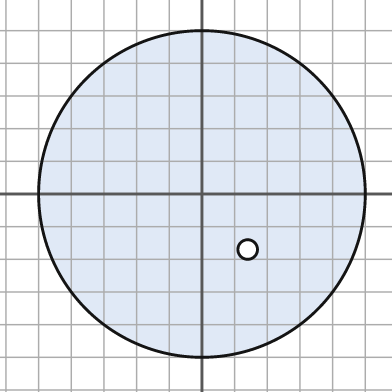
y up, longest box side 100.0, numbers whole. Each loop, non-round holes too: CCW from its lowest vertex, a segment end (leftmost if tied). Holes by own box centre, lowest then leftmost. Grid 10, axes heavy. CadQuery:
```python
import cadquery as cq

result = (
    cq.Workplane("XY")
    .moveTo(0.0, 0.0)
    .circle(50.0)
    .moveTo(14.0, -17.0)
    .circle(3.0)
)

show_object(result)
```